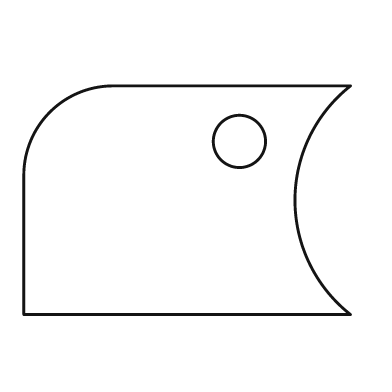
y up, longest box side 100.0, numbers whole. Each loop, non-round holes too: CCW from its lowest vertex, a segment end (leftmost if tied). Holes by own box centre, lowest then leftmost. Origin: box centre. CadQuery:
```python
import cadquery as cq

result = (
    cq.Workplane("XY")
    .moveTo(-50.0, -35.0)
    .lineTo(50.0, -35.0)
    .threePointArc((33.0, 0.0), (50.0, 35.0))
    .lineTo(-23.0, 35.0)
    .threePointArc((-42.0, 27.0), (-50.0, 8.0))
    .close()
    .moveTo(16.0, 18.0)
    .circle(8.0)
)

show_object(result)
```